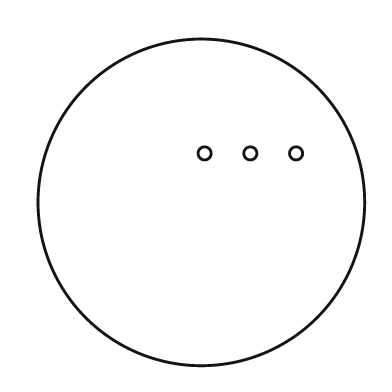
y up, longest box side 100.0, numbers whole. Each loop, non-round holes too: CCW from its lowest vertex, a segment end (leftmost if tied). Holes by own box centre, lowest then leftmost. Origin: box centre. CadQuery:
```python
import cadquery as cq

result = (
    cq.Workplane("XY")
    .moveTo(0.0, 0.0)
    .circle(50.0)
    .moveTo(1.0, 15.0)
    .circle(2.0)
    .moveTo(15.0, 15.0)
    .circle(2.0)
    .moveTo(29.0, 15.0)
    .circle(2.0)
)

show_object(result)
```